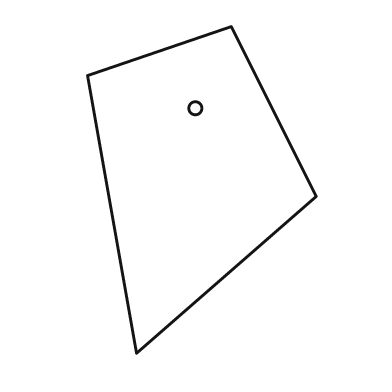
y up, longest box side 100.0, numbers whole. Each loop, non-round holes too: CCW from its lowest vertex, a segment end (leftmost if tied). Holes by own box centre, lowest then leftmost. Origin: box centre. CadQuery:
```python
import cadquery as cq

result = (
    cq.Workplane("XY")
    .moveTo(-20.0, -50.0)
    .lineTo(35.0, -2.0)
    .lineTo(9.0, 50.0)
    .lineTo(-35.0, 35.0)
    .close()
    .moveTo(-2.0, 25.0)
    .circle(2.0)
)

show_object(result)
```